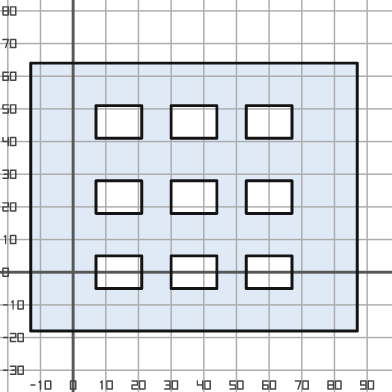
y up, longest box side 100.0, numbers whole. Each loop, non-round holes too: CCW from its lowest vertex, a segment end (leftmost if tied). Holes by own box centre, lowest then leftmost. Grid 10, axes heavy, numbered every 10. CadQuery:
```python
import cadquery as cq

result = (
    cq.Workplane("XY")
    .moveTo(-13.0, -18.0)
    .lineTo(87.0, -18.0)
    .lineTo(87.0, 64.0)
    .lineTo(-13.0, 64.0)
    .close()
    .moveTo(7.0, -5.0)
    .lineTo(21.0, -5.0)
    .lineTo(21.0, 5.0)
    .lineTo(7.0, 5.0)
    .close()
    .moveTo(30.0, -5.0)
    .lineTo(44.0, -5.0)
    .lineTo(44.0, 5.0)
    .lineTo(30.0, 5.0)
    .close()
    .moveTo(53.0, -5.0)
    .lineTo(67.0, -5.0)
    .lineTo(67.0, 5.0)
    .lineTo(53.0, 5.0)
    .close()
    .moveTo(7.0, 18.0)
    .lineTo(21.0, 18.0)
    .lineTo(21.0, 28.0)
    .lineTo(7.0, 28.0)
    .close()
    .moveTo(30.0, 18.0)
    .lineTo(44.0, 18.0)
    .lineTo(44.0, 28.0)
    .lineTo(30.0, 28.0)
    .close()
    .moveTo(53.0, 18.0)
    .lineTo(67.0, 18.0)
    .lineTo(67.0, 28.0)
    .lineTo(53.0, 28.0)
    .close()
    .moveTo(7.0, 41.0)
    .lineTo(21.0, 41.0)
    .lineTo(21.0, 51.0)
    .lineTo(7.0, 51.0)
    .close()
    .moveTo(30.0, 41.0)
    .lineTo(44.0, 41.0)
    .lineTo(44.0, 51.0)
    .lineTo(30.0, 51.0)
    .close()
    .moveTo(53.0, 41.0)
    .lineTo(67.0, 41.0)
    .lineTo(67.0, 51.0)
    .lineTo(53.0, 51.0)
    .close()
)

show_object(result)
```